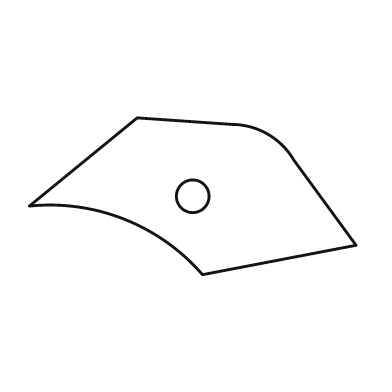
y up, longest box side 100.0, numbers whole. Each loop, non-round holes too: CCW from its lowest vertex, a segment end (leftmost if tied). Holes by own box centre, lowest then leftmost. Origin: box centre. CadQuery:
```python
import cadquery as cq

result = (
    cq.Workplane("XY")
    .moveTo(3.0, -24.0)
    .lineTo(50.0, -15.0)
    .lineTo(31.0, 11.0)
    .threePointArc((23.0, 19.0), (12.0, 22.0))
    .lineTo(-17.0, 24.0)
    .lineTo(-50.0, -3.0)
    .threePointArc((-21.0, -7.0), (3.0, -24.0))
    .close()
    .moveTo(0.0, 0.0)
    .circle(5.0)
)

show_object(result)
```